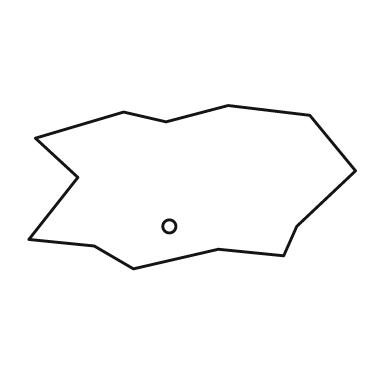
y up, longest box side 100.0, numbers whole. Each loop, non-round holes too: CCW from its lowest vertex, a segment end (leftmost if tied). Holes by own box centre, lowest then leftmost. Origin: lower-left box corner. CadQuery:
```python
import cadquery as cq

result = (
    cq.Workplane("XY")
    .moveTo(32.0, 0.0)
    .lineTo(58.0, 6.0)
    .lineTo(78.0, 4.0)
    .lineTo(82.0, 13.0)
    .lineTo(100.0, 30.0)
    .lineTo(86.0, 47.0)
    .lineTo(61.0, 50.0)
    .lineTo(42.0, 45.0)
    .lineTo(29.0, 48.0)
    .lineTo(2.0, 40.0)
    .lineTo(15.0, 28.0)
    .lineTo(0.0, 9.0)
    .lineTo(20.0, 7.0)
    .close()
    .moveTo(43.0, 13.0)
    .circle(2.0)
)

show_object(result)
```